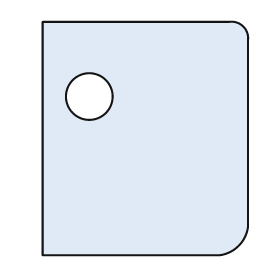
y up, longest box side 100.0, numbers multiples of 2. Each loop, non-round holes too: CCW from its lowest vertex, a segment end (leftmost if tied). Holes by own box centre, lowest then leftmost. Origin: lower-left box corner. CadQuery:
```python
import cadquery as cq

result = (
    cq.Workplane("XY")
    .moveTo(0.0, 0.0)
    .lineTo(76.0, 0.0)
    .threePointArc((84.0, 4.0), (88.0, 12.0))
    .lineTo(88.0, 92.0)
    .threePointArc((86.0, 98.0), (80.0, 100.0))
    .lineTo(0.0, 100.0)
    .close()
    .moveTo(20.0, 68.0)
    .circle(10.0)
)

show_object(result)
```